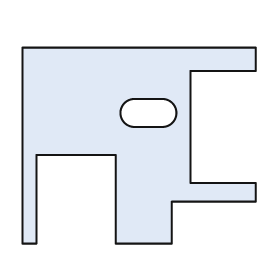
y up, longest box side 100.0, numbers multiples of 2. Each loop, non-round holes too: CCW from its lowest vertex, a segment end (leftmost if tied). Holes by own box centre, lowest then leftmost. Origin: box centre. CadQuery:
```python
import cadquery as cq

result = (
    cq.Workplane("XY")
    .moveTo(-50.0, -42.0)
    .lineTo(-44.0, -42.0)
    .lineTo(-44.0, -4.0)
    .lineTo(-10.0, -4.0)
    .lineTo(-10.0, -42.0)
    .lineTo(14.0, -42.0)
    .lineTo(14.0, -24.0)
    .lineTo(50.0, -24.0)
    .lineTo(50.0, -16.0)
    .lineTo(22.0, -16.0)
    .lineTo(22.0, 32.0)
    .lineTo(50.0, 32.0)
    .lineTo(50.0, 42.0)
    .lineTo(-50.0, 42.0)
    .close()
    .moveTo(-2.0, 8.0)
    .lineTo(10.0, 8.0)
    .threePointArc((16.0, 14.0), (10.0, 20.0))
    .lineTo(-2.0, 20.0)
    .threePointArc((-8.0, 14.0), (-2.0, 8.0))
    .close()
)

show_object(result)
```